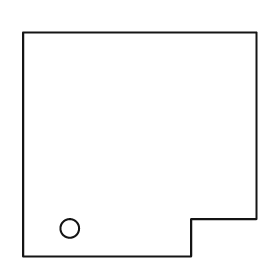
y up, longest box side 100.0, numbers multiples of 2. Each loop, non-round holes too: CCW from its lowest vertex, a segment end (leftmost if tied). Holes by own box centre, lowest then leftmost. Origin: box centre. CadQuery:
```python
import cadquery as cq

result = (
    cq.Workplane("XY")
    .moveTo(-50.0, -48.0)
    .lineTo(22.0, -48.0)
    .lineTo(22.0, -32.0)
    .lineTo(50.0, -32.0)
    .lineTo(50.0, 48.0)
    .lineTo(-50.0, 48.0)
    .close()
    .moveTo(-30.0, -36.0)
    .circle(4.0)
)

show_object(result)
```